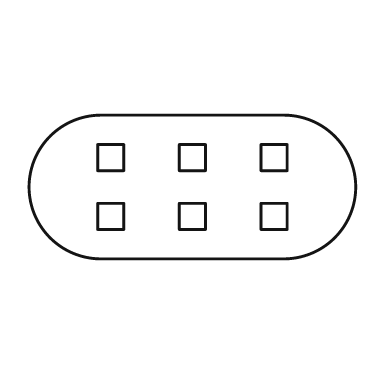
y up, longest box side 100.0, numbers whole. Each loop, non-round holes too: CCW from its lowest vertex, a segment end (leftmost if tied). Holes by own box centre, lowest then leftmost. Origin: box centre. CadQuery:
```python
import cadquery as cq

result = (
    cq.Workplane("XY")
    .moveTo(-28.0, -22.0)
    .lineTo(28.0, -22.0)
    .threePointArc((50.0, 0.0), (28.0, 22.0))
    .lineTo(-28.0, 22.0)
    .threePointArc((-50.0, 0.0), (-28.0, -22.0))
    .close()
    .moveTo(-29.0, -13.0)
    .lineTo(-21.0, -13.0)
    .lineTo(-21.0, -5.0)
    .lineTo(-29.0, -5.0)
    .close()
    .moveTo(-4.0, -13.0)
    .lineTo(4.0, -13.0)
    .lineTo(4.0, -5.0)
    .lineTo(-4.0, -5.0)
    .close()
    .moveTo(21.0, -13.0)
    .lineTo(29.0, -13.0)
    .lineTo(29.0, -5.0)
    .lineTo(21.0, -5.0)
    .close()
    .moveTo(-29.0, 5.0)
    .lineTo(-21.0, 5.0)
    .lineTo(-21.0, 13.0)
    .lineTo(-29.0, 13.0)
    .close()
    .moveTo(-4.0, 5.0)
    .lineTo(4.0, 5.0)
    .lineTo(4.0, 13.0)
    .lineTo(-4.0, 13.0)
    .close()
    .moveTo(21.0, 5.0)
    .lineTo(29.0, 5.0)
    .lineTo(29.0, 13.0)
    .lineTo(21.0, 13.0)
    .close()
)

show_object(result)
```